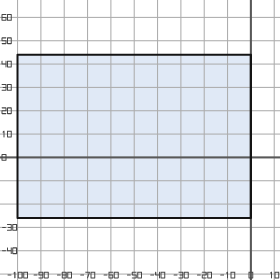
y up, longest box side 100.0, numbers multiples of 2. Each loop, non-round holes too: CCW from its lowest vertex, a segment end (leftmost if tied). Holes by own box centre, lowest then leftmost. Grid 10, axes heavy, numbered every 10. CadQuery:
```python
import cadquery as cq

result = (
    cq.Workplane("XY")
    .moveTo(-100.0, -26.0)
    .lineTo(0.0, -26.0)
    .lineTo(0.0, 44.0)
    .lineTo(-100.0, 44.0)
    .close()
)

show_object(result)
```